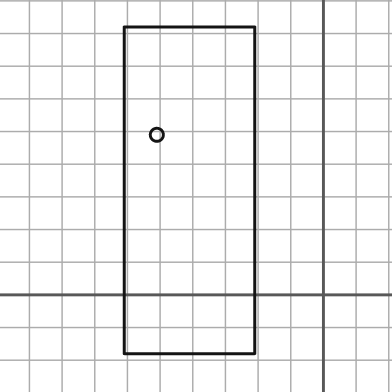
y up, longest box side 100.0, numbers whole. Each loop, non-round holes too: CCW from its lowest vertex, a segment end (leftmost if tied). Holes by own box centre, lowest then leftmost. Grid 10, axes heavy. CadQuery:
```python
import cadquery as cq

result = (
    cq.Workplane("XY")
    .moveTo(-61.0, -18.0)
    .lineTo(-21.0, -18.0)
    .lineTo(-21.0, 82.0)
    .lineTo(-61.0, 82.0)
    .close()
    .moveTo(-51.0, 49.0)
    .circle(2.0)
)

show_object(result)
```